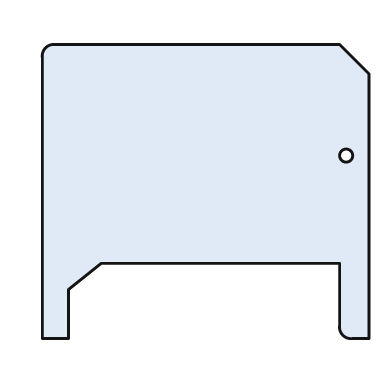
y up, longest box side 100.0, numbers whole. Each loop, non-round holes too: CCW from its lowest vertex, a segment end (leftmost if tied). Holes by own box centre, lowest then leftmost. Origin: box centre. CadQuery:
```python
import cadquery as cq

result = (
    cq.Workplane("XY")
    .moveTo(-50.0, -45.0)
    .lineTo(-42.0, -45.0)
    .lineTo(-42.0, -30.0)
    .lineTo(-32.0, -22.0)
    .lineTo(41.0, -22.0)
    .lineTo(41.0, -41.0)
    .threePointArc((42.0, -44.0), (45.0, -45.0))
    .lineTo(50.0, -45.0)
    .lineTo(50.0, 36.0)
    .lineTo(41.0, 45.0)
    .lineTo(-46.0, 45.0)
    .threePointArc((-49.0, 44.0), (-50.0, 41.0))
    .close()
    .moveTo(43.0, 11.0)
    .circle(2.0)
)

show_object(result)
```